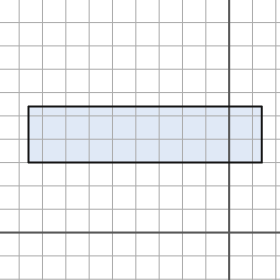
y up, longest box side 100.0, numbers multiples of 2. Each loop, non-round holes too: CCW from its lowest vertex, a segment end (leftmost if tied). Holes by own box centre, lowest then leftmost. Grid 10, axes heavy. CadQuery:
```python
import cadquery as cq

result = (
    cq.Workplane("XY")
    .moveTo(-86.0, 30.0)
    .lineTo(14.0, 30.0)
    .lineTo(14.0, 54.0)
    .lineTo(-86.0, 54.0)
    .close()
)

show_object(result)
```